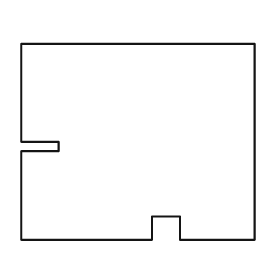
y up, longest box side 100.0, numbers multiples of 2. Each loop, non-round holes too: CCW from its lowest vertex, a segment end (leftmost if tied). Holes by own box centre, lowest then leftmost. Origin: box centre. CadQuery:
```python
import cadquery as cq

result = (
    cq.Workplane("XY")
    .moveTo(-50.0, -42.0)
    .lineTo(6.0, -42.0)
    .lineTo(6.0, -32.0)
    .lineTo(18.0, -32.0)
    .lineTo(18.0, -42.0)
    .lineTo(50.0, -42.0)
    .lineTo(50.0, 42.0)
    .lineTo(-50.0, 42.0)
    .lineTo(-50.0, 0.0)
    .lineTo(-34.0, 0.0)
    .lineTo(-34.0, -4.0)
    .lineTo(-50.0, -4.0)
    .close()
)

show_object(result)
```